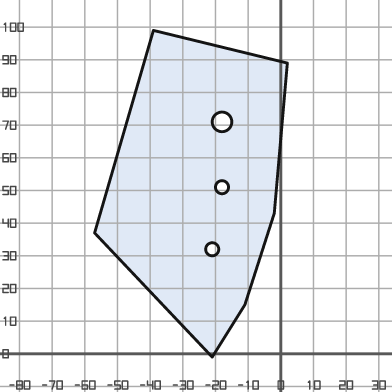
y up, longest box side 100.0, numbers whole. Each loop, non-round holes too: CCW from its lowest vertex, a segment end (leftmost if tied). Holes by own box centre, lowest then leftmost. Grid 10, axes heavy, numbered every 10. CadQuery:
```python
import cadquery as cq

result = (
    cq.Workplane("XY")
    .moveTo(-21.0, -1.0)
    .lineTo(-11.0, 15.0)
    .lineTo(-2.0, 43.0)
    .lineTo(2.0, 89.0)
    .lineTo(-39.0, 99.0)
    .lineTo(-57.0, 37.0)
    .close()
    .moveTo(-21.0, 32.0)
    .circle(2.0)
    .moveTo(-18.0, 51.0)
    .circle(2.0)
    .moveTo(-18.0, 71.0)
    .circle(3.0)
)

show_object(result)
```